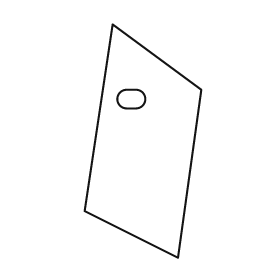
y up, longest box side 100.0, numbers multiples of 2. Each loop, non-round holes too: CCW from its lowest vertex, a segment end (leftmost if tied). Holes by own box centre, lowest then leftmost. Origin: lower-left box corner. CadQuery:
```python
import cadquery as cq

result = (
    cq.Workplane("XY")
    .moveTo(40.0, 0.0)
    .lineTo(50.0, 72.0)
    .lineTo(12.0, 100.0)
    .lineTo(0.0, 20.0)
    .close()
    .moveTo(18.0, 64.0)
    .lineTo(22.0, 64.0)
    .threePointArc((26.0, 68.0), (22.0, 72.0))
    .lineTo(18.0, 72.0)
    .threePointArc((14.0, 68.0), (18.0, 64.0))
    .close()
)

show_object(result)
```